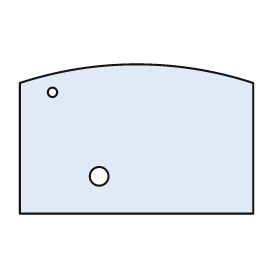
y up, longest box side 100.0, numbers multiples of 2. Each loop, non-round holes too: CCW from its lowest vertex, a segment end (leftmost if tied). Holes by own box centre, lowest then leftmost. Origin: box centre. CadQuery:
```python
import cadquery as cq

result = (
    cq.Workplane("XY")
    .moveTo(-50.0, -32.0)
    .lineTo(50.0, -32.0)
    .lineTo(50.0, 24.0)
    .threePointArc((0.0, 32.0), (-50.0, 24.0))
    .close()
    .moveTo(-16.0, -16.0)
    .circle(4.0)
    .moveTo(-36.0, 20.0)
    .circle(2.0)
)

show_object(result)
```